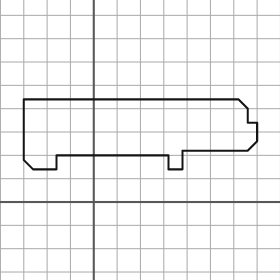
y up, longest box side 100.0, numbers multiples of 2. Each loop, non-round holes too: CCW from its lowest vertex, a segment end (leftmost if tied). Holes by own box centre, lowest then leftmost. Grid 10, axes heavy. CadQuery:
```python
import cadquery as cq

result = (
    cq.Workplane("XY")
    .moveTo(-26.0, 14.0)
    .lineTo(-16.0, 14.0)
    .lineTo(-16.0, 20.0)
    .lineTo(32.0, 20.0)
    .lineTo(32.0, 14.0)
    .lineTo(38.0, 14.0)
    .lineTo(38.0, 22.0)
    .lineTo(66.0, 22.0)
    .lineTo(70.0, 26.0)
    .lineTo(70.0, 34.0)
    .lineTo(66.0, 34.0)
    .lineTo(66.0, 40.0)
    .lineTo(62.0, 44.0)
    .lineTo(-30.0, 44.0)
    .lineTo(-30.0, 18.0)
    .close()
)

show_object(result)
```